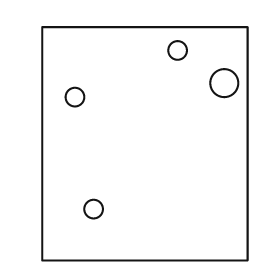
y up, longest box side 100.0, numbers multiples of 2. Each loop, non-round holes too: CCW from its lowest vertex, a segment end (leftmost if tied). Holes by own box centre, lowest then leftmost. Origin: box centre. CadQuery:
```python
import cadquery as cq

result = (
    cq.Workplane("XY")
    .moveTo(-44.0, -50.0)
    .lineTo(44.0, -50.0)
    .lineTo(44.0, 50.0)
    .lineTo(-44.0, 50.0)
    .close()
    .moveTo(-22.0, -28.0)
    .circle(4.0)
    .moveTo(-30.0, 20.0)
    .circle(4.0)
    .moveTo(34.0, 26.0)
    .circle(6.0)
    .moveTo(14.0, 40.0)
    .circle(4.0)
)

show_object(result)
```